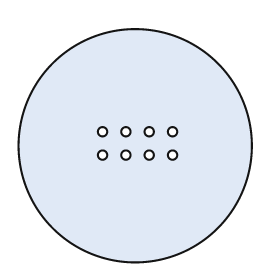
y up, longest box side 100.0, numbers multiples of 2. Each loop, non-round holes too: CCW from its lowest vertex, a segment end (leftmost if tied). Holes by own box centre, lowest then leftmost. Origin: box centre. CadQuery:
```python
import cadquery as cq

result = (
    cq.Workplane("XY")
    .moveTo(0.0, 0.0)
    .circle(50.0)
    .moveTo(-14.0, -4.0)
    .circle(2.0)
    .moveTo(-4.0, -4.0)
    .circle(2.0)
    .moveTo(6.0, -4.0)
    .circle(2.0)
    .moveTo(16.0, -4.0)
    .circle(2.0)
    .moveTo(-14.0, 6.0)
    .circle(2.0)
    .moveTo(-4.0, 6.0)
    .circle(2.0)
    .moveTo(6.0, 6.0)
    .circle(2.0)
    .moveTo(16.0, 6.0)
    .circle(2.0)
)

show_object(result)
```